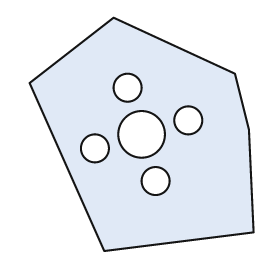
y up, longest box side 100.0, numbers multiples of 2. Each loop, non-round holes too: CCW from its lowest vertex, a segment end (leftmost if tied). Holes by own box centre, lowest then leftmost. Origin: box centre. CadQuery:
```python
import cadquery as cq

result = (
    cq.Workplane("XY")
    .moveTo(-16.0, -50.0)
    .lineTo(48.0, -42.0)
    .lineTo(46.0, 2.0)
    .lineTo(40.0, 26.0)
    .lineTo(-12.0, 50.0)
    .lineTo(-48.0, 22.0)
    .close()
    .moveTo(6.0, -20.0)
    .circle(6.0)
    .moveTo(-20.0, -6.0)
    .circle(6.0)
    .moveTo(0.0, 0.0)
    .circle(10.0)
    .moveTo(20.0, 6.0)
    .circle(6.0)
    .moveTo(-6.0, 20.0)
    .circle(6.0)
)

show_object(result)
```